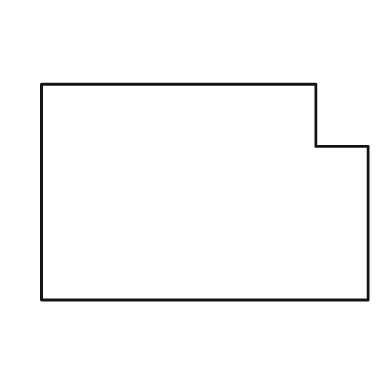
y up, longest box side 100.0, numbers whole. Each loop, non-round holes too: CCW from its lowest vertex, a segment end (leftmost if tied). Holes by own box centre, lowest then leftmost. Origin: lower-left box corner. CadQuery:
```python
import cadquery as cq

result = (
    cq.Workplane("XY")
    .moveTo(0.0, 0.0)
    .lineTo(100.0, 0.0)
    .lineTo(100.0, 47.0)
    .lineTo(84.0, 47.0)
    .lineTo(84.0, 66.0)
    .lineTo(0.0, 66.0)
    .close()
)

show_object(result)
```